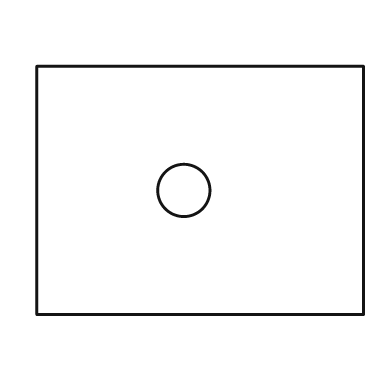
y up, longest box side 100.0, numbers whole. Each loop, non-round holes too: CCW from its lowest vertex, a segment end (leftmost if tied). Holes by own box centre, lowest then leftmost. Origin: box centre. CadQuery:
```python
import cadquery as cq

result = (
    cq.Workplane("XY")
    .moveTo(-50.0, -38.0)
    .lineTo(50.0, -38.0)
    .lineTo(50.0, 38.0)
    .lineTo(-50.0, 38.0)
    .close()
    .moveTo(-5.0, 0.0)
    .circle(8.0)
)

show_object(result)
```